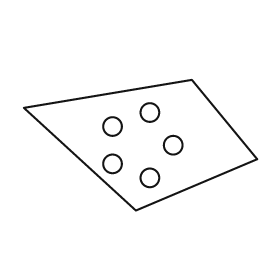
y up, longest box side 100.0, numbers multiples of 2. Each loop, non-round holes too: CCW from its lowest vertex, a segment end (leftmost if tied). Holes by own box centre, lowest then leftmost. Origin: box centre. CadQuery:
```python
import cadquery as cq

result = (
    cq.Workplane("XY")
    .moveTo(-2.0, -28.0)
    .lineTo(50.0, -6.0)
    .lineTo(22.0, 28.0)
    .lineTo(-50.0, 16.0)
    .close()
    .moveTo(4.0, -14.0)
    .circle(4.0)
    .moveTo(-12.0, -8.0)
    .circle(4.0)
    .moveTo(14.0, 0.0)
    .circle(4.0)
    .moveTo(-12.0, 8.0)
    .circle(4.0)
    .moveTo(4.0, 14.0)
    .circle(4.0)
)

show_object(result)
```